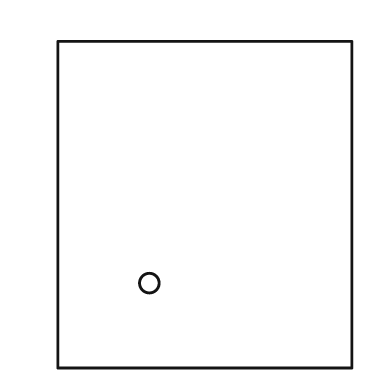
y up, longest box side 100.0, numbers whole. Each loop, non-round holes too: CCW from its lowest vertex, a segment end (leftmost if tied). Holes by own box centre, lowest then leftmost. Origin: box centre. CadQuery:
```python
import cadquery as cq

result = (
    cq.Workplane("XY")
    .moveTo(-45.0, -50.0)
    .lineTo(45.0, -50.0)
    .lineTo(45.0, 50.0)
    .lineTo(-45.0, 50.0)
    .close()
    .moveTo(-17.0, -24.0)
    .circle(3.0)
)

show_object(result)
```